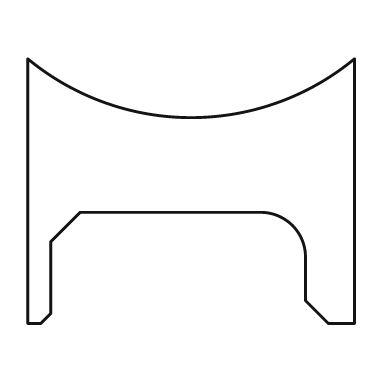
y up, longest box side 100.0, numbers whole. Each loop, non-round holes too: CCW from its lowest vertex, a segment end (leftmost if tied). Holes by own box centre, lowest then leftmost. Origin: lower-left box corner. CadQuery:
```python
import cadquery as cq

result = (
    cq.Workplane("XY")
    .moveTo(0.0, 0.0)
    .lineTo(4.0, 0.0)
    .lineTo(7.0, 3.0)
    .lineTo(7.0, 25.0)
    .lineTo(16.0, 34.0)
    .lineTo(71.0, 34.0)
    .threePointArc((81.0, 30.0), (85.0, 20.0))
    .lineTo(85.0, 7.0)
    .lineTo(92.0, 0.0)
    .lineTo(100.0, 0.0)
    .lineTo(100.0, 81.0)
    .threePointArc((50.0, 63.0), (0.0, 81.0))
    .close()
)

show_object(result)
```